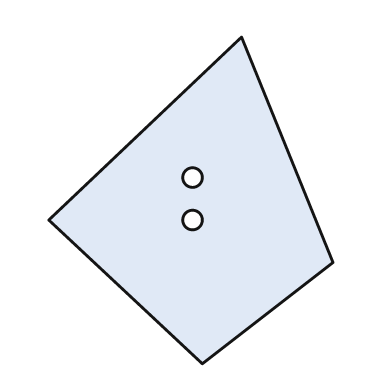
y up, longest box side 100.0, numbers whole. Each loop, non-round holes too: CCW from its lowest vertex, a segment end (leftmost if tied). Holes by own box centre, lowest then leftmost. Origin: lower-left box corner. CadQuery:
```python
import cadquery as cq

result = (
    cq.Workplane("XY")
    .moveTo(47.0, 0.0)
    .lineTo(87.0, 31.0)
    .lineTo(59.0, 100.0)
    .lineTo(0.0, 44.0)
    .close()
    .moveTo(44.0, 44.0)
    .circle(3.0)
    .moveTo(44.0, 57.0)
    .circle(3.0)
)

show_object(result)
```